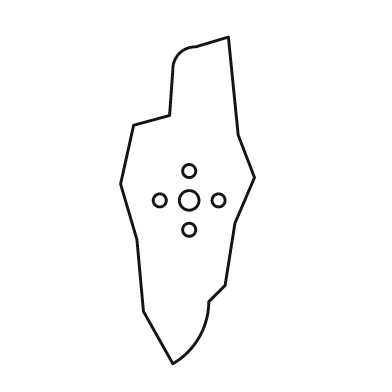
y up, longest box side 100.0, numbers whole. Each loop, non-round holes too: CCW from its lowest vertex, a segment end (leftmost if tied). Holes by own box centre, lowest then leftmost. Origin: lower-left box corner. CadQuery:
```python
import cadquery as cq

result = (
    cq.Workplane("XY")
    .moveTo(16.0, 0.0)
    .threePointArc((24.0, 8.0), (27.0, 19.0))
    .lineTo(32.0, 24.0)
    .lineTo(35.0, 43.0)
    .lineTo(41.0, 57.0)
    .lineTo(36.0, 70.0)
    .lineTo(33.0, 100.0)
    .lineTo(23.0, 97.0)
    .threePointArc((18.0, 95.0), (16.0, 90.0))
    .lineTo(15.0, 76.0)
    .lineTo(4.0, 73.0)
    .lineTo(0.0, 55.0)
    .lineTo(5.0, 38.0)
    .lineTo(7.0, 16.0)
    .close()
    .moveTo(21.0, 41.0)
    .circle(2.0)
    .moveTo(12.0, 50.0)
    .circle(2.0)
    .moveTo(21.0, 50.0)
    .circle(3.0)
    .moveTo(30.0, 50.0)
    .circle(2.0)
    .moveTo(21.0, 59.0)
    .circle(2.0)
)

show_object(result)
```